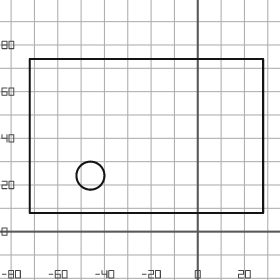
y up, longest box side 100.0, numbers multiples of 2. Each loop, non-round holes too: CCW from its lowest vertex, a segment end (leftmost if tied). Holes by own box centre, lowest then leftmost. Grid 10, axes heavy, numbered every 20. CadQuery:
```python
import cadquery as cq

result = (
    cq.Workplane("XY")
    .moveTo(-72.0, 8.0)
    .lineTo(28.0, 8.0)
    .lineTo(28.0, 74.0)
    .lineTo(-72.0, 74.0)
    .close()
    .moveTo(-46.0, 24.0)
    .circle(6.0)
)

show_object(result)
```